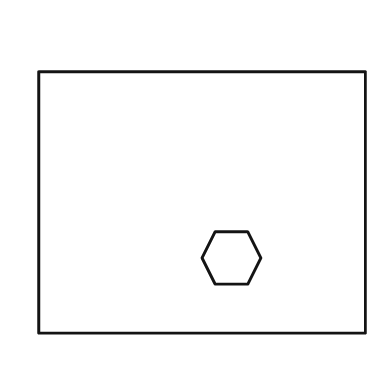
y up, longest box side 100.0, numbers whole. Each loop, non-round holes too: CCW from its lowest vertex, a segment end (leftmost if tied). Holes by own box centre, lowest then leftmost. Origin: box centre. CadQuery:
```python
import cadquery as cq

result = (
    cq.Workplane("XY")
    .moveTo(-50.0, -40.0)
    .lineTo(50.0, -40.0)
    .lineTo(50.0, 40.0)
    .lineTo(-50.0, 40.0)
    .close()
    .moveTo(4.0, -25.0)
    .lineTo(14.0, -25.0)
    .lineTo(18.0, -17.0)
    .lineTo(14.0, -9.0)
    .lineTo(4.0, -9.0)
    .lineTo(0.0, -17.0)
    .close()
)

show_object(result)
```